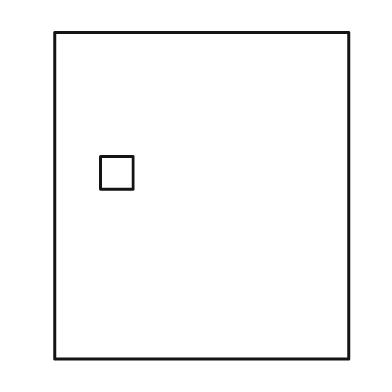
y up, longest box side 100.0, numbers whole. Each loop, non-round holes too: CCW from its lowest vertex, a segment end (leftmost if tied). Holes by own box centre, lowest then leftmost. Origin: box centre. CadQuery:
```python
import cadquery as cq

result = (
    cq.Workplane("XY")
    .moveTo(-45.0, -50.0)
    .lineTo(45.0, -50.0)
    .lineTo(45.0, 50.0)
    .lineTo(-45.0, 50.0)
    .close()
    .moveTo(-31.0, 2.0)
    .lineTo(-21.0, 2.0)
    .lineTo(-21.0, 12.0)
    .lineTo(-31.0, 12.0)
    .close()
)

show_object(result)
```